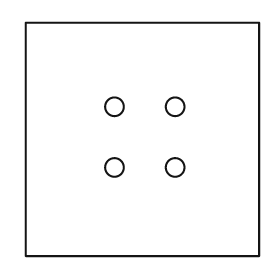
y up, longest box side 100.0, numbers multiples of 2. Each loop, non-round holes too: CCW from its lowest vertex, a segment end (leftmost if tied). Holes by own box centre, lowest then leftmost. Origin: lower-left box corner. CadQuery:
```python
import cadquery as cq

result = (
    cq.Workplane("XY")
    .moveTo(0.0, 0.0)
    .lineTo(100.0, 0.0)
    .lineTo(100.0, 100.0)
    .lineTo(0.0, 100.0)
    .close()
    .moveTo(38.0, 38.0)
    .circle(4.0)
    .moveTo(64.0, 38.0)
    .circle(4.0)
    .moveTo(38.0, 64.0)
    .circle(4.0)
    .moveTo(64.0, 64.0)
    .circle(4.0)
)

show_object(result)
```